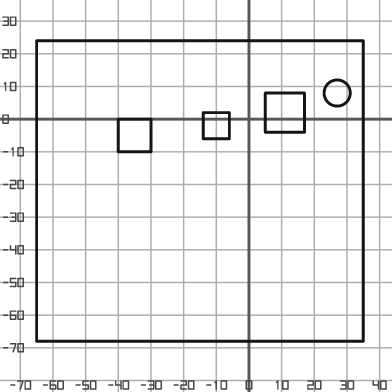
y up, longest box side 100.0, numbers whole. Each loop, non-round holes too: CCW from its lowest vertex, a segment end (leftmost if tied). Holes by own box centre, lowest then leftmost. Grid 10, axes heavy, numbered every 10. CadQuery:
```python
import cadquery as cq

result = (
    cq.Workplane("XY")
    .moveTo(-65.0, -68.0)
    .lineTo(35.0, -68.0)
    .lineTo(35.0, 24.0)
    .lineTo(-65.0, 24.0)
    .close()
    .moveTo(-40.0, -10.0)
    .lineTo(-30.0, -10.0)
    .lineTo(-30.0, 0.0)
    .lineTo(-40.0, 0.0)
    .close()
    .moveTo(-14.0, -6.0)
    .lineTo(-6.0, -6.0)
    .lineTo(-6.0, 2.0)
    .lineTo(-14.0, 2.0)
    .close()
    .moveTo(5.0, -4.0)
    .lineTo(17.0, -4.0)
    .lineTo(17.0, 8.0)
    .lineTo(5.0, 8.0)
    .close()
    .moveTo(27.0, 8.0)
    .circle(4.0)
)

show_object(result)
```